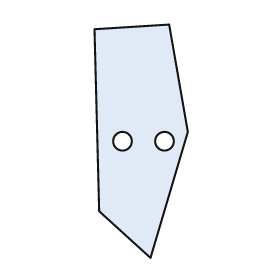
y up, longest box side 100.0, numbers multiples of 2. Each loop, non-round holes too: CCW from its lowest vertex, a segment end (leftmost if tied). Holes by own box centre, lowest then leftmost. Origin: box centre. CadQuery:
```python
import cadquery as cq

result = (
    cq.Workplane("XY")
    .moveTo(4.0, -50.0)
    .lineTo(20.0, 4.0)
    .lineTo(12.0, 50.0)
    .lineTo(-20.0, 48.0)
    .lineTo(-18.0, -30.0)
    .close()
    .moveTo(-8.0, 0.0)
    .circle(4.0)
    .moveTo(10.0, 0.0)
    .circle(4.0)
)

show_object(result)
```